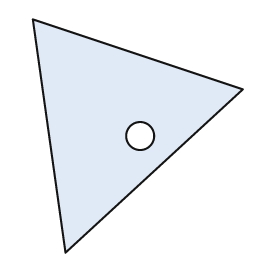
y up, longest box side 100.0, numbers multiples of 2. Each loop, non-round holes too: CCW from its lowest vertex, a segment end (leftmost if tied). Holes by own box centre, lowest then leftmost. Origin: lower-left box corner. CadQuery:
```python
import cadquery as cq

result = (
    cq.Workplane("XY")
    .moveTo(14.0, 0.0)
    .lineTo(90.0, 70.0)
    .lineTo(0.0, 100.0)
    .close()
    .moveTo(46.0, 50.0)
    .circle(6.0)
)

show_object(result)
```